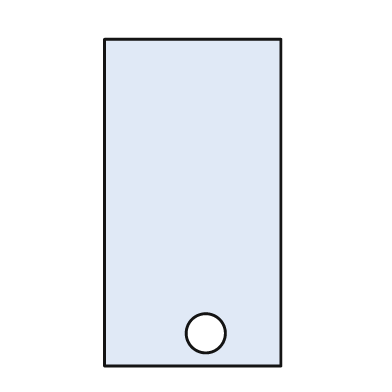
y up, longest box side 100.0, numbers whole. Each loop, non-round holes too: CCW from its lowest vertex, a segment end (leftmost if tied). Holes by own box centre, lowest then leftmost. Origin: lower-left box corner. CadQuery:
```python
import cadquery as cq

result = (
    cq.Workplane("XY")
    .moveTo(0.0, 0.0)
    .lineTo(54.0, 0.0)
    .lineTo(54.0, 100.0)
    .lineTo(0.0, 100.0)
    .close()
    .moveTo(31.0, 10.0)
    .circle(6.0)
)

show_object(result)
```